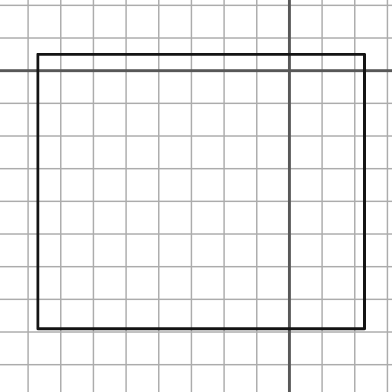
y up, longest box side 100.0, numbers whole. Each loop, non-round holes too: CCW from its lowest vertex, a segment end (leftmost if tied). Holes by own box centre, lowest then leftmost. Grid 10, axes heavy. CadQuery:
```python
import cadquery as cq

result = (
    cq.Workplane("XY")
    .moveTo(-77.0, -79.0)
    .lineTo(23.0, -79.0)
    .lineTo(23.0, 5.0)
    .lineTo(-77.0, 5.0)
    .close()
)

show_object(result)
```